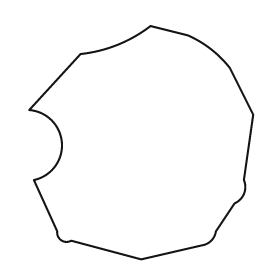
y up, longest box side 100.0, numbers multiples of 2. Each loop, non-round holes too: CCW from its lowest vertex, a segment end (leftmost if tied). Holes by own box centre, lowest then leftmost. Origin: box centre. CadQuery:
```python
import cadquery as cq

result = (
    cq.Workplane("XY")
    .moveTo(0.0, -50.0)
    .lineTo(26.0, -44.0)
    .threePointArc((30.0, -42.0), (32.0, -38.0))
    .lineTo(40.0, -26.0)
    .threePointArc((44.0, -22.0), (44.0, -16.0))
    .lineTo(48.0, 12.0)
    .lineTo(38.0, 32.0)
    .threePointArc((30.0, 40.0), (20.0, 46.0))
    .lineTo(4.0, 50.0)
    .threePointArc((-10.0, 42.0), (-26.0, 38.0))
    .lineTo(-48.0, 14.0)
    .threePointArc((-34.0, 0.0), (-46.0, -16.0))
    .lineTo(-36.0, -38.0)
    .threePointArc((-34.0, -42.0), (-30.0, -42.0))
    .close()
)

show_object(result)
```